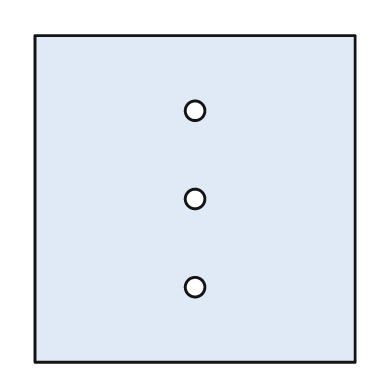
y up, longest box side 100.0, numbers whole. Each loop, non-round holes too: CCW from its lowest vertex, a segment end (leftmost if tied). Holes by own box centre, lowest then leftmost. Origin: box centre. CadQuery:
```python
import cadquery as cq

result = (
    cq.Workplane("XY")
    .moveTo(-49.0, -50.0)
    .lineTo(49.0, -50.0)
    .lineTo(49.0, 50.0)
    .lineTo(-49.0, 50.0)
    .close()
    .moveTo(0.0, -27.0)
    .circle(3.0)
    .moveTo(0.0, 0.0)
    .circle(3.0)
    .moveTo(0.0, 27.0)
    .circle(3.0)
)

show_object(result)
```